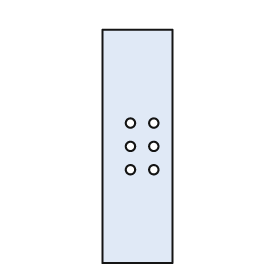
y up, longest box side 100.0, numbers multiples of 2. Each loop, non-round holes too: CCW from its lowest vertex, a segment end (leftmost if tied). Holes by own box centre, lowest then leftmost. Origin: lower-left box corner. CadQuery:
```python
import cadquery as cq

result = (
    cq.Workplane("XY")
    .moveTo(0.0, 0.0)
    .lineTo(30.0, 0.0)
    .lineTo(30.0, 100.0)
    .lineTo(0.0, 100.0)
    .close()
    .moveTo(12.0, 40.0)
    .circle(2.0)
    .moveTo(22.0, 40.0)
    .circle(2.0)
    .moveTo(12.0, 50.0)
    .circle(2.0)
    .moveTo(22.0, 50.0)
    .circle(2.0)
    .moveTo(12.0, 60.0)
    .circle(2.0)
    .moveTo(22.0, 60.0)
    .circle(2.0)
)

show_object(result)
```